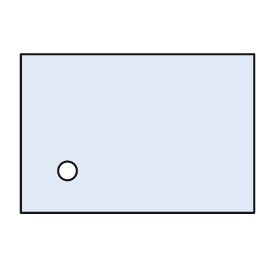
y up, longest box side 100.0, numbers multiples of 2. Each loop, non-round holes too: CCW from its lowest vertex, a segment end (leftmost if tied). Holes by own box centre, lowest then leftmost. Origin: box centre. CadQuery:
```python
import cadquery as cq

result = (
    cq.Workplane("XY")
    .moveTo(-50.0, -34.0)
    .lineTo(50.0, -34.0)
    .lineTo(50.0, 34.0)
    .lineTo(-50.0, 34.0)
    .close()
    .moveTo(-30.0, -16.0)
    .circle(4.0)
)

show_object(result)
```